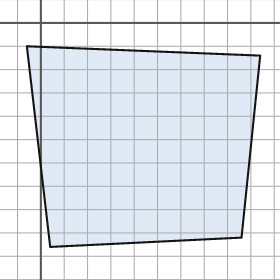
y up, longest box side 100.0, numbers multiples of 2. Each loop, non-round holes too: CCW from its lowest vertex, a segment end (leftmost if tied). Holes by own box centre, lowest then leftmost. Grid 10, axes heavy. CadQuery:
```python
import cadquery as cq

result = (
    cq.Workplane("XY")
    .moveTo(4.0, -96.0)
    .lineTo(86.0, -92.0)
    .lineTo(94.0, -14.0)
    .lineTo(-6.0, -10.0)
    .close()
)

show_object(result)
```